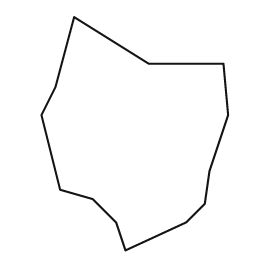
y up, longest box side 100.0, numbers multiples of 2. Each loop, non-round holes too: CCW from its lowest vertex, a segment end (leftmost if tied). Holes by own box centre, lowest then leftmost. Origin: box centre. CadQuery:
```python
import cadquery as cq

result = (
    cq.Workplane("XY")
    .moveTo(-4.0, -50.0)
    .lineTo(22.0, -38.0)
    .lineTo(30.0, -30.0)
    .lineTo(32.0, -16.0)
    .lineTo(40.0, 8.0)
    .lineTo(38.0, 30.0)
    .lineTo(6.0, 30.0)
    .lineTo(-26.0, 50.0)
    .lineTo(-34.0, 20.0)
    .lineTo(-40.0, 8.0)
    .lineTo(-32.0, -24.0)
    .lineTo(-18.0, -28.0)
    .lineTo(-8.0, -38.0)
    .close()
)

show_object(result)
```